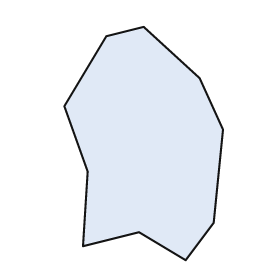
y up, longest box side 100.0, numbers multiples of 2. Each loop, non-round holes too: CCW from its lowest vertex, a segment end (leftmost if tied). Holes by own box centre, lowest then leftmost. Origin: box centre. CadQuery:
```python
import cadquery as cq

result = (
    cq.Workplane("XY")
    .moveTo(18.0, -50.0)
    .lineTo(30.0, -34.0)
    .lineTo(34.0, 6.0)
    .lineTo(24.0, 28.0)
    .lineTo(0.0, 50.0)
    .lineTo(-16.0, 46.0)
    .lineTo(-34.0, 16.0)
    .lineTo(-24.0, -12.0)
    .lineTo(-26.0, -44.0)
    .lineTo(-2.0, -38.0)
    .close()
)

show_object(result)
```